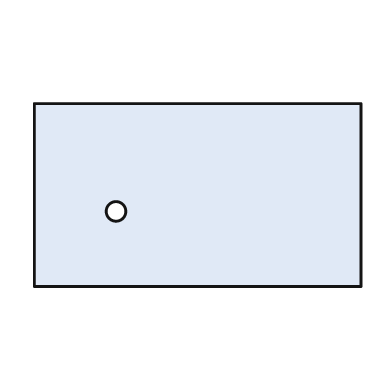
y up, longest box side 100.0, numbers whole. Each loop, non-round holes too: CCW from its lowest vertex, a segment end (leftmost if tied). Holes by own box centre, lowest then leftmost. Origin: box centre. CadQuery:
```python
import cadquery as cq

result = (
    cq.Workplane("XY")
    .moveTo(-50.0, -28.0)
    .lineTo(50.0, -28.0)
    .lineTo(50.0, 28.0)
    .lineTo(-50.0, 28.0)
    .close()
    .moveTo(-25.0, -5.0)
    .circle(3.0)
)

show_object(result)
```